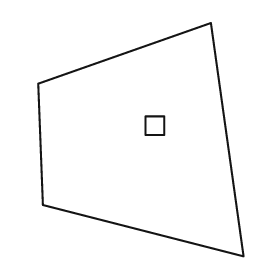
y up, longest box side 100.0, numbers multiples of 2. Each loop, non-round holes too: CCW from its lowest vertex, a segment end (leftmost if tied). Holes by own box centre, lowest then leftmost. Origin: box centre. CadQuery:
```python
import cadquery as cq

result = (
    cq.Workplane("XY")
    .moveTo(44.0, -50.0)
    .lineTo(30.0, 50.0)
    .lineTo(-44.0, 24.0)
    .lineTo(-42.0, -28.0)
    .close()
    .moveTo(2.0, 2.0)
    .lineTo(10.0, 2.0)
    .lineTo(10.0, 10.0)
    .lineTo(2.0, 10.0)
    .close()
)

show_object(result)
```